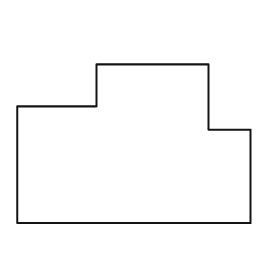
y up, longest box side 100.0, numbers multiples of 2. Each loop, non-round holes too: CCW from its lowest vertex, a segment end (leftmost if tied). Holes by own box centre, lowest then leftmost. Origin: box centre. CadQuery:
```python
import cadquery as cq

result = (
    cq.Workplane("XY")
    .moveTo(-50.0, -34.0)
    .lineTo(50.0, -34.0)
    .lineTo(50.0, 6.0)
    .lineTo(32.0, 6.0)
    .lineTo(32.0, 34.0)
    .lineTo(-16.0, 34.0)
    .lineTo(-16.0, 16.0)
    .lineTo(-50.0, 16.0)
    .close()
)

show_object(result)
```